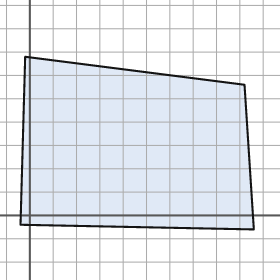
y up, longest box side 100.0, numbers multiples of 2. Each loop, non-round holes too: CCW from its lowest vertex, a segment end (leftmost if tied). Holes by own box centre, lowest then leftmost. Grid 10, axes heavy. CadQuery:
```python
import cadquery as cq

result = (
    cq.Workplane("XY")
    .moveTo(96.0, -6.0)
    .lineTo(92.0, 56.0)
    .lineTo(-2.0, 68.0)
    .lineTo(-4.0, -4.0)
    .close()
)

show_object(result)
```